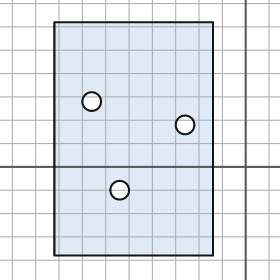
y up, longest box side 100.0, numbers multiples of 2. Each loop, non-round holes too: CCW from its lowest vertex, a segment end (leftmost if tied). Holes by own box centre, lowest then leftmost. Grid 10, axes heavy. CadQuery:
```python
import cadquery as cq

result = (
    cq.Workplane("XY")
    .moveTo(-82.0, -38.0)
    .lineTo(-14.0, -38.0)
    .lineTo(-14.0, 62.0)
    .lineTo(-82.0, 62.0)
    .close()
    .moveTo(-54.0, -10.0)
    .circle(4.0)
    .moveTo(-26.0, 18.0)
    .circle(4.0)
    .moveTo(-66.0, 28.0)
    .circle(4.0)
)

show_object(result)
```